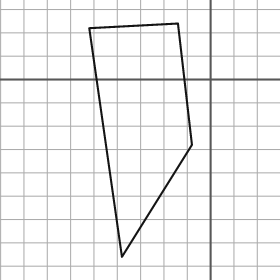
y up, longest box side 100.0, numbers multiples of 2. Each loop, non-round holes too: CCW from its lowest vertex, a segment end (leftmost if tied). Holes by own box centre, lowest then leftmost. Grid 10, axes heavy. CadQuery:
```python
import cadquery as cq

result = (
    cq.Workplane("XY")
    .moveTo(-38.0, -76.0)
    .lineTo(-8.0, -28.0)
    .lineTo(-14.0, 24.0)
    .lineTo(-52.0, 22.0)
    .close()
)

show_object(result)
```